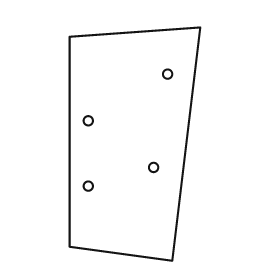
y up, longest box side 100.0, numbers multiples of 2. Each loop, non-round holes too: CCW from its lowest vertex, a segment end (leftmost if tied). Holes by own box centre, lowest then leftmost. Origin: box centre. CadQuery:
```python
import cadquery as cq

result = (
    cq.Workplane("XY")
    .moveTo(16.0, -50.0)
    .lineTo(28.0, 50.0)
    .lineTo(-28.0, 46.0)
    .lineTo(-28.0, -44.0)
    .close()
    .moveTo(-20.0, -18.0)
    .circle(2.0)
    .moveTo(8.0, -10.0)
    .circle(2.0)
    .moveTo(-20.0, 10.0)
    .circle(2.0)
    .moveTo(14.0, 30.0)
    .circle(2.0)
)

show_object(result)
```